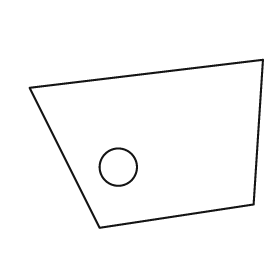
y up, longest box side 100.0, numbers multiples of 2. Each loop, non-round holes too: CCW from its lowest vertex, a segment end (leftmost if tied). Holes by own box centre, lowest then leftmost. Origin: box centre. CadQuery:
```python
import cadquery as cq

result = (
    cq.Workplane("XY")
    .moveTo(-20.0, -36.0)
    .lineTo(46.0, -26.0)
    .lineTo(50.0, 36.0)
    .lineTo(-50.0, 24.0)
    .close()
    .moveTo(-12.0, -10.0)
    .circle(8.0)
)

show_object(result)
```